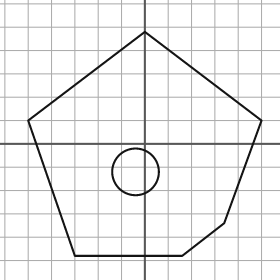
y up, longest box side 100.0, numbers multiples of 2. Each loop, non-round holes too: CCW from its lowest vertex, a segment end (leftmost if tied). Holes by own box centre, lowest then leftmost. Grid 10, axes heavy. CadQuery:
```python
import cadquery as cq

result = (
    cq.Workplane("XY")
    .moveTo(-30.0, -48.0)
    .lineTo(16.0, -48.0)
    .lineTo(34.0, -34.0)
    .lineTo(50.0, 10.0)
    .lineTo(0.0, 48.0)
    .lineTo(-50.0, 10.0)
    .close()
    .moveTo(-4.0, -12.0)
    .circle(10.0)
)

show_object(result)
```